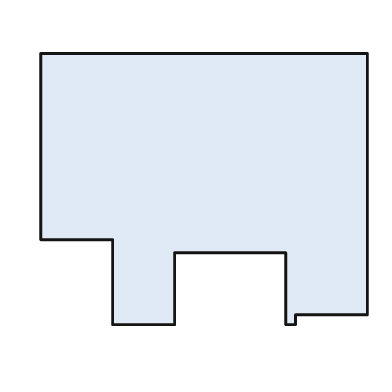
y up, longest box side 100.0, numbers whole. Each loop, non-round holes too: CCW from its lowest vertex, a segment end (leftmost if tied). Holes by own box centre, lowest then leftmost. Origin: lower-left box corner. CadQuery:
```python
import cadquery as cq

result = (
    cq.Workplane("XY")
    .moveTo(22.0, 0.0)
    .lineTo(41.0, 0.0)
    .lineTo(41.0, 22.0)
    .lineTo(75.0, 22.0)
    .lineTo(75.0, 0.0)
    .lineTo(78.0, 0.0)
    .lineTo(78.0, 3.0)
    .lineTo(100.0, 3.0)
    .lineTo(100.0, 83.0)
    .lineTo(0.0, 83.0)
    .lineTo(0.0, 26.0)
    .lineTo(22.0, 26.0)
    .close()
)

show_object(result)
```